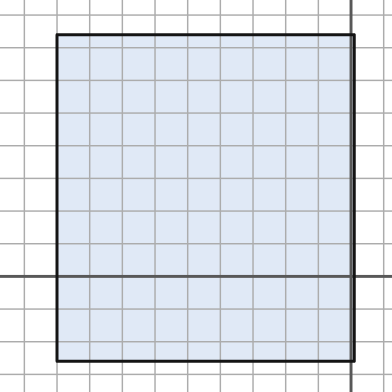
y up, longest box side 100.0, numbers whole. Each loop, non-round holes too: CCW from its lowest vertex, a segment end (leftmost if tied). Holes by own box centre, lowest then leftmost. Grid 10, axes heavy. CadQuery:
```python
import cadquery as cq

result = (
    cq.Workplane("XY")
    .moveTo(-90.0, -26.0)
    .lineTo(1.0, -26.0)
    .lineTo(1.0, 74.0)
    .lineTo(-90.0, 74.0)
    .close()
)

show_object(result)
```